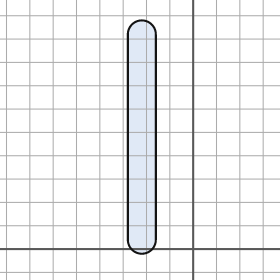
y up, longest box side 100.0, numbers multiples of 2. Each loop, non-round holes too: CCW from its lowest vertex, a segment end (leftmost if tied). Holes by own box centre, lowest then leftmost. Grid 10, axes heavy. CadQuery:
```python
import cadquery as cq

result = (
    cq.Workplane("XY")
    .moveTo(-28.0, 4.0)
    .threePointArc((-22.0, -2.0), (-16.0, 4.0))
    .lineTo(-16.0, 92.0)
    .threePointArc((-22.0, 98.0), (-28.0, 92.0))
    .close()
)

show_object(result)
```